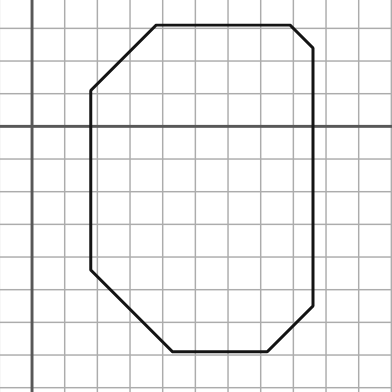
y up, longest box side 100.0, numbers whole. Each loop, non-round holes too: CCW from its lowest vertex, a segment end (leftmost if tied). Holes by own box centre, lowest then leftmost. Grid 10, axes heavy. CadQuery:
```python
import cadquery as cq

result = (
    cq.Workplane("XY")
    .moveTo(43.0, -69.0)
    .lineTo(72.0, -69.0)
    .lineTo(86.0, -55.0)
    .lineTo(86.0, 24.0)
    .lineTo(79.0, 31.0)
    .lineTo(38.0, 31.0)
    .lineTo(18.0, 11.0)
    .lineTo(18.0, -44.0)
    .close()
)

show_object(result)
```